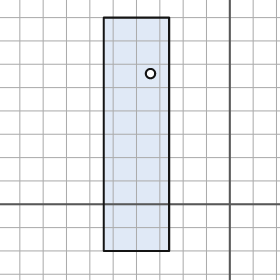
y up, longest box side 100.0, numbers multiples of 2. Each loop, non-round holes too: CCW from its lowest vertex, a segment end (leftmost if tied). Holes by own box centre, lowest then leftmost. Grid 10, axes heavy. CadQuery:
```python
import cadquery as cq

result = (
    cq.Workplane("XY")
    .moveTo(-54.0, -20.0)
    .lineTo(-26.0, -20.0)
    .lineTo(-26.0, 80.0)
    .lineTo(-54.0, 80.0)
    .close()
    .moveTo(-34.0, 56.0)
    .circle(2.0)
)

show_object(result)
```